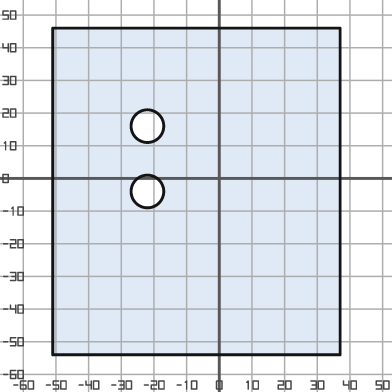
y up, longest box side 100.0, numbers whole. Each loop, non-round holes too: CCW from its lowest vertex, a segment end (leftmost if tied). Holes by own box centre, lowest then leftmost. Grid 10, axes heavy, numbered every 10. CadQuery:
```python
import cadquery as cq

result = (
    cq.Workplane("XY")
    .moveTo(-51.0, -54.0)
    .lineTo(37.0, -54.0)
    .lineTo(37.0, 46.0)
    .lineTo(-51.0, 46.0)
    .close()
    .moveTo(-22.0, -4.0)
    .circle(5.0)
    .moveTo(-22.0, 16.0)
    .circle(5.0)
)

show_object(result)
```